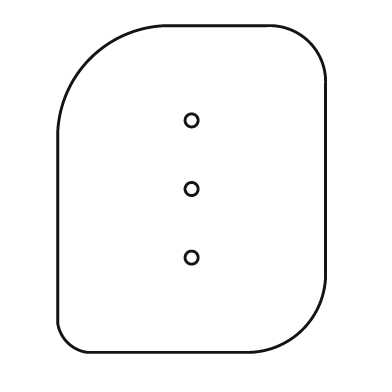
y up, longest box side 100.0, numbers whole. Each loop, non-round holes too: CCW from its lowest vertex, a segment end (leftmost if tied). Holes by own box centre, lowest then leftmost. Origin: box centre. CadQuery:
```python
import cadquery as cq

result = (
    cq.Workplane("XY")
    .moveTo(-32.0, -50.0)
    .lineTo(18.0, -50.0)
    .threePointArc((34.0, -43.0), (41.0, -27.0))
    .lineTo(41.0, 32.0)
    .threePointArc((36.0, 45.0), (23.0, 50.0))
    .lineTo(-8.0, 50.0)
    .threePointArc((-31.0, 40.0), (-41.0, 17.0))
    .lineTo(-41.0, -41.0)
    .threePointArc((-38.0, -47.0), (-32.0, -50.0))
    .close()
    .moveTo(0.0, -21.0)
    .circle(2.0)
    .moveTo(0.0, 0.0)
    .circle(2.0)
    .moveTo(0.0, 21.0)
    .circle(2.0)
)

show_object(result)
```